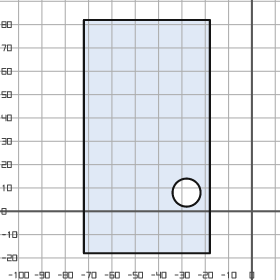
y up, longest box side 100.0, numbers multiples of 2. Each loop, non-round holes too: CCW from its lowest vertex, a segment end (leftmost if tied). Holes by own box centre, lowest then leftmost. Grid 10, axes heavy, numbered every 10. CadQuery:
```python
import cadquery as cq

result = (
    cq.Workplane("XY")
    .moveTo(-72.0, -18.0)
    .lineTo(-18.0, -18.0)
    .lineTo(-18.0, 82.0)
    .lineTo(-72.0, 82.0)
    .close()
    .moveTo(-28.0, 8.0)
    .circle(6.0)
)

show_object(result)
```